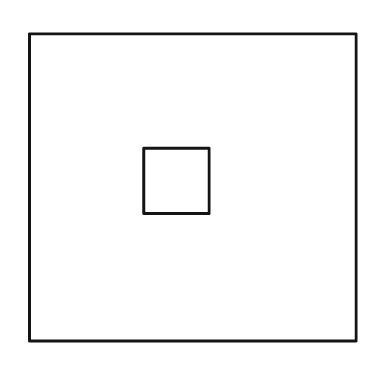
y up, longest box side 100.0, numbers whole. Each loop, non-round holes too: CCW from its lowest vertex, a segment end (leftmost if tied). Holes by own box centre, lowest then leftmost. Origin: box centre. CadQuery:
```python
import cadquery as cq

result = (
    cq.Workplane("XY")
    .moveTo(-50.0, -47.0)
    .lineTo(50.0, -47.0)
    .lineTo(50.0, 47.0)
    .lineTo(-50.0, 47.0)
    .close()
    .moveTo(-15.0, -8.0)
    .lineTo(5.0, -8.0)
    .lineTo(5.0, 12.0)
    .lineTo(-15.0, 12.0)
    .close()
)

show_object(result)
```